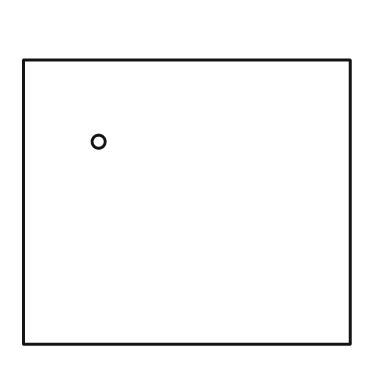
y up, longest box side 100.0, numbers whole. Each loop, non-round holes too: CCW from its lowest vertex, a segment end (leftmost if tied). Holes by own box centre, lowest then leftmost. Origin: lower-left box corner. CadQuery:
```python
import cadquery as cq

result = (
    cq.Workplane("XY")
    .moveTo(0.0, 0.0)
    .lineTo(100.0, 0.0)
    .lineTo(100.0, 87.0)
    .lineTo(0.0, 87.0)
    .close()
    .moveTo(23.0, 62.0)
    .circle(2.0)
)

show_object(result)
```